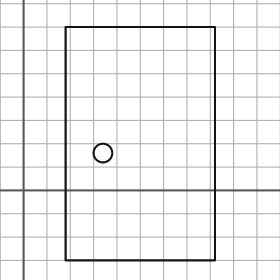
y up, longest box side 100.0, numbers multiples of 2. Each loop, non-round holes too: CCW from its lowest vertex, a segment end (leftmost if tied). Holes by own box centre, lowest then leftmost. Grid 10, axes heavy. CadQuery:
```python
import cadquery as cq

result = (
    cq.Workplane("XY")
    .moveTo(18.0, -30.0)
    .lineTo(82.0, -30.0)
    .lineTo(82.0, 70.0)
    .lineTo(18.0, 70.0)
    .close()
    .moveTo(34.0, 16.0)
    .circle(4.0)
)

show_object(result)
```